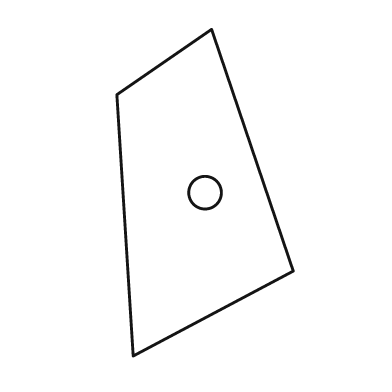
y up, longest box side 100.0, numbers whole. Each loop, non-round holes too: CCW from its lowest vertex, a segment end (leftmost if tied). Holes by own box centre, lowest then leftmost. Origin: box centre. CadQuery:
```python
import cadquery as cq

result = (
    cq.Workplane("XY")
    .moveTo(-22.0, -50.0)
    .lineTo(27.0, -24.0)
    .lineTo(2.0, 50.0)
    .lineTo(-27.0, 30.0)
    .close()
    .moveTo(0.0, 0.0)
    .circle(5.0)
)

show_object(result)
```